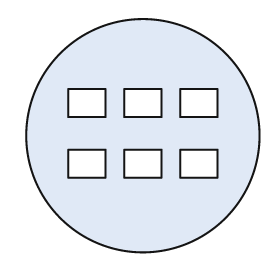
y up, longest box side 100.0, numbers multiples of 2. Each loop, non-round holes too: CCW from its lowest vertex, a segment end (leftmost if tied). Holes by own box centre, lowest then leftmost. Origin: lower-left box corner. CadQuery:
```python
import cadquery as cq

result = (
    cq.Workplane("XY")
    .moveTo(50.0, 50.0)
    .circle(50.0)
    .moveTo(18.0, 32.0)
    .lineTo(34.0, 32.0)
    .lineTo(34.0, 44.0)
    .lineTo(18.0, 44.0)
    .close()
    .moveTo(42.0, 32.0)
    .lineTo(58.0, 32.0)
    .lineTo(58.0, 44.0)
    .lineTo(42.0, 44.0)
    .close()
    .moveTo(66.0, 32.0)
    .lineTo(82.0, 32.0)
    .lineTo(82.0, 44.0)
    .lineTo(66.0, 44.0)
    .close()
    .moveTo(18.0, 58.0)
    .lineTo(34.0, 58.0)
    .lineTo(34.0, 70.0)
    .lineTo(18.0, 70.0)
    .close()
    .moveTo(42.0, 58.0)
    .lineTo(58.0, 58.0)
    .lineTo(58.0, 70.0)
    .lineTo(42.0, 70.0)
    .close()
    .moveTo(66.0, 58.0)
    .lineTo(82.0, 58.0)
    .lineTo(82.0, 70.0)
    .lineTo(66.0, 70.0)
    .close()
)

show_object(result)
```